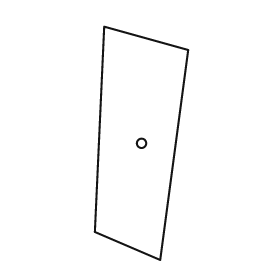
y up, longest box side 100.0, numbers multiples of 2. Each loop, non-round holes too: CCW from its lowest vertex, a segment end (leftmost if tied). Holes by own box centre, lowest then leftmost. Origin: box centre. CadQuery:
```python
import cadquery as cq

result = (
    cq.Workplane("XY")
    .moveTo(8.0, -50.0)
    .lineTo(20.0, 40.0)
    .lineTo(-16.0, 50.0)
    .lineTo(-20.0, -38.0)
    .close()
    .moveTo(0.0, 0.0)
    .circle(2.0)
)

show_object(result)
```